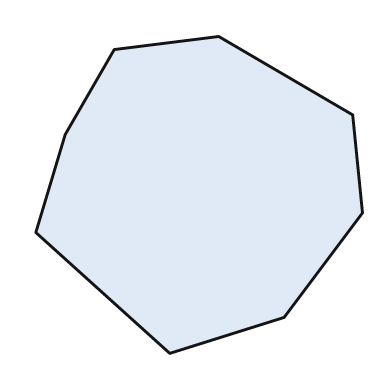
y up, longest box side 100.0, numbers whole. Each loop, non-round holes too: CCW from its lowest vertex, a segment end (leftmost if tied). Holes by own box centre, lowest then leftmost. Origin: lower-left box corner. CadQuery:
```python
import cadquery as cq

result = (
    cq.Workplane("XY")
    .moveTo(41.0, 0.0)
    .lineTo(76.0, 11.0)
    .lineTo(100.0, 43.0)
    .lineTo(97.0, 73.0)
    .lineTo(56.0, 97.0)
    .lineTo(24.0, 93.0)
    .lineTo(9.0, 67.0)
    .lineTo(0.0, 37.0)
    .close()
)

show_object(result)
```